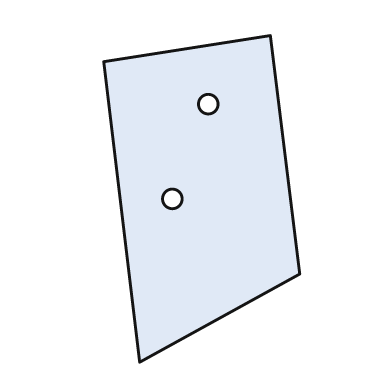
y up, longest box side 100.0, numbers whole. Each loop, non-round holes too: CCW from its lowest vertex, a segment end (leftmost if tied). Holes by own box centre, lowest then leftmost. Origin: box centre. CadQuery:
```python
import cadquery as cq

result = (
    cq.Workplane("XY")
    .moveTo(-19.0, -50.0)
    .lineTo(30.0, -23.0)
    .lineTo(21.0, 50.0)
    .lineTo(-30.0, 42.0)
    .close()
    .moveTo(-9.0, 0.0)
    .circle(3.0)
    .moveTo(2.0, 29.0)
    .circle(3.0)
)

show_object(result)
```